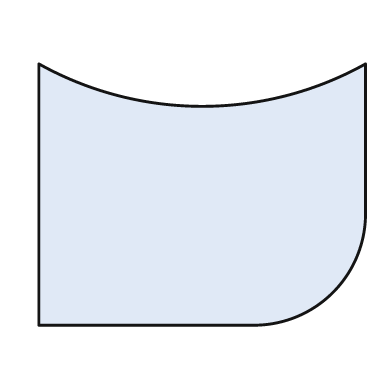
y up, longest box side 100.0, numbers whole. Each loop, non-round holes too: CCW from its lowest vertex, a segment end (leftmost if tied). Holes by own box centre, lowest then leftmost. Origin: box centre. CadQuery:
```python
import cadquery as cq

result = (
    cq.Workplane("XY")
    .moveTo(-50.0, -40.0)
    .lineTo(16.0, -40.0)
    .threePointArc((40.0, -30.0), (50.0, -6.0))
    .lineTo(50.0, 40.0)
    .threePointArc((0.0, 27.0), (-50.0, 40.0))
    .close()
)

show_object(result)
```